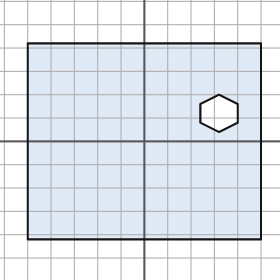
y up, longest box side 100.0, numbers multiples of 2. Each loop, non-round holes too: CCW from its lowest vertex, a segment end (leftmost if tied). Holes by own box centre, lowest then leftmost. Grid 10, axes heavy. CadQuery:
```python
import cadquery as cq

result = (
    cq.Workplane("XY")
    .moveTo(-50.0, -42.0)
    .lineTo(50.0, -42.0)
    .lineTo(50.0, 42.0)
    .lineTo(-50.0, 42.0)
    .close()
    .moveTo(32.0, 4.0)
    .lineTo(40.0, 8.0)
    .lineTo(40.0, 16.0)
    .lineTo(32.0, 20.0)
    .lineTo(24.0, 16.0)
    .lineTo(24.0, 8.0)
    .close()
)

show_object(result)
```